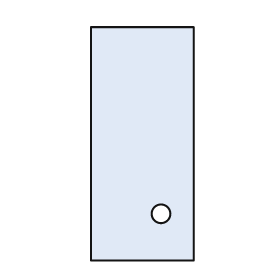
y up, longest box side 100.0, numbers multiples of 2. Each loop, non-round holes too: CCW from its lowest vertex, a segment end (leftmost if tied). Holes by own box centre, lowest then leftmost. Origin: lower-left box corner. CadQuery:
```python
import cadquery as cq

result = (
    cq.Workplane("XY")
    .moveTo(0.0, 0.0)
    .lineTo(44.0, 0.0)
    .lineTo(44.0, 100.0)
    .lineTo(0.0, 100.0)
    .close()
    .moveTo(30.0, 20.0)
    .circle(4.0)
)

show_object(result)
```